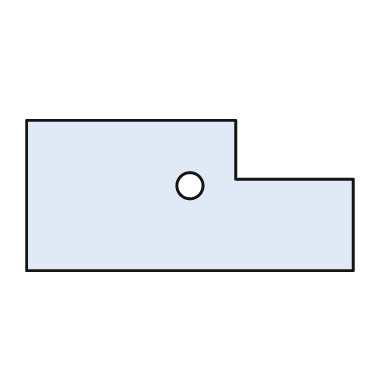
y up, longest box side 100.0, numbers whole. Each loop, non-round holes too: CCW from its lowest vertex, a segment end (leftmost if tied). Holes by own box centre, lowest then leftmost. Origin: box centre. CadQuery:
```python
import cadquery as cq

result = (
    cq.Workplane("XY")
    .moveTo(-50.0, -23.0)
    .lineTo(50.0, -23.0)
    .lineTo(50.0, 5.0)
    .lineTo(14.0, 5.0)
    .lineTo(14.0, 23.0)
    .lineTo(-50.0, 23.0)
    .close()
    .moveTo(0.0, 3.0)
    .circle(4.0)
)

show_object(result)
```